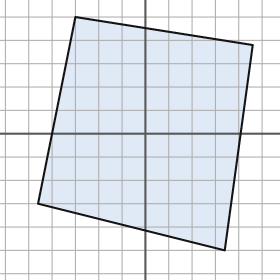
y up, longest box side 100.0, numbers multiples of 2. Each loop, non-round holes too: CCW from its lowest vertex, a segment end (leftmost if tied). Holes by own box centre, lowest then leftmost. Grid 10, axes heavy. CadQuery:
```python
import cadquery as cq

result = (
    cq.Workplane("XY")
    .moveTo(34.0, -50.0)
    .lineTo(46.0, 38.0)
    .lineTo(-30.0, 50.0)
    .lineTo(-46.0, -30.0)
    .close()
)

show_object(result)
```